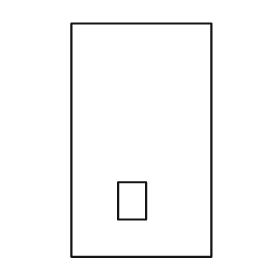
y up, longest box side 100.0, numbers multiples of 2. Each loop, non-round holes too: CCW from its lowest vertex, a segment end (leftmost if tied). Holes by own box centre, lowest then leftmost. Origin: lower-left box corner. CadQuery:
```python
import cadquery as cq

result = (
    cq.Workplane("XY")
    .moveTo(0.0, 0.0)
    .lineTo(60.0, 0.0)
    .lineTo(60.0, 100.0)
    .lineTo(0.0, 100.0)
    .close()
    .moveTo(20.0, 16.0)
    .lineTo(32.0, 16.0)
    .lineTo(32.0, 32.0)
    .lineTo(20.0, 32.0)
    .close()
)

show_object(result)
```